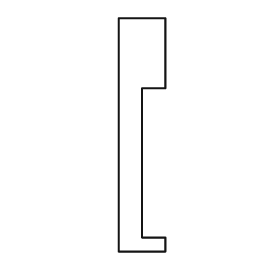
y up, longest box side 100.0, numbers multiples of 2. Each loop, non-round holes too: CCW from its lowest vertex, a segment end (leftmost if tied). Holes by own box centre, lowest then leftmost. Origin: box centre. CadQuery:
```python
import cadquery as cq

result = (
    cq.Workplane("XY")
    .moveTo(-10.0, -50.0)
    .lineTo(10.0, -50.0)
    .lineTo(10.0, -44.0)
    .lineTo(0.0, -44.0)
    .lineTo(0.0, 20.0)
    .lineTo(10.0, 20.0)
    .lineTo(10.0, 50.0)
    .lineTo(-10.0, 50.0)
    .close()
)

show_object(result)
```